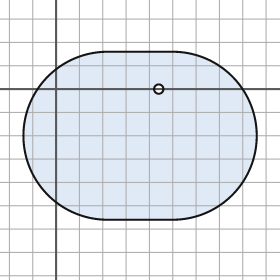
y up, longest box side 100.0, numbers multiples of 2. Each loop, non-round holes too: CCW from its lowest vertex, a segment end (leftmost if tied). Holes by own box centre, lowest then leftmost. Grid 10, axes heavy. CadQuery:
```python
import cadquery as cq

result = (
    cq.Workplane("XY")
    .moveTo(22.0, -56.0)
    .lineTo(50.0, -56.0)
    .threePointArc((86.0, -20.0), (50.0, 16.0))
    .lineTo(22.0, 16.0)
    .threePointArc((-14.0, -20.0), (22.0, -56.0))
    .close()
    .moveTo(44.0, 0.0)
    .circle(2.0)
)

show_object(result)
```